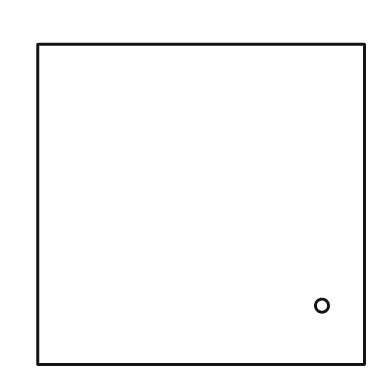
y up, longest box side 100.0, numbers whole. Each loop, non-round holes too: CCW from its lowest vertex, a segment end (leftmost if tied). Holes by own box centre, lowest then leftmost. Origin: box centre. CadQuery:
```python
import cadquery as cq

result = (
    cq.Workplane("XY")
    .moveTo(-50.0, -49.0)
    .lineTo(50.0, -49.0)
    .lineTo(50.0, 49.0)
    .lineTo(-50.0, 49.0)
    .close()
    .moveTo(37.0, -31.0)
    .circle(2.0)
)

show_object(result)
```